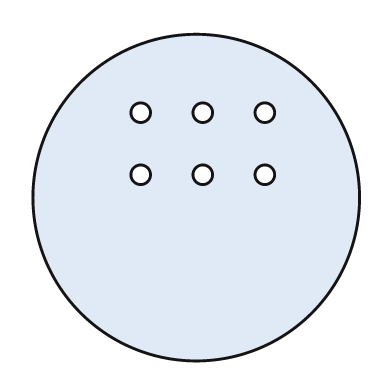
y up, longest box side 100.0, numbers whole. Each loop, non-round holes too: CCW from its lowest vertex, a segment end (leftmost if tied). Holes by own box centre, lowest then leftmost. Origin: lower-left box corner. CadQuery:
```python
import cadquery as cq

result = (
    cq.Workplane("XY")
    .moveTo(50.0, 50.0)
    .circle(50.0)
    .moveTo(33.0, 57.0)
    .circle(3.0)
    .moveTo(52.0, 57.0)
    .circle(3.0)
    .moveTo(71.0, 57.0)
    .circle(3.0)
    .moveTo(33.0, 76.0)
    .circle(3.0)
    .moveTo(52.0, 76.0)
    .circle(3.0)
    .moveTo(71.0, 76.0)
    .circle(3.0)
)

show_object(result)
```